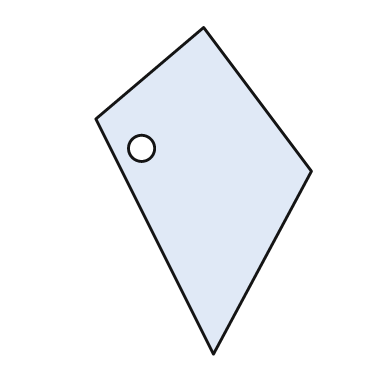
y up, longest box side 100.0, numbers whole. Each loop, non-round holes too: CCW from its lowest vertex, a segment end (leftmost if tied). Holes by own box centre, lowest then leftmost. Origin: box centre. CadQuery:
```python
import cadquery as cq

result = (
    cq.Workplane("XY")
    .moveTo(3.0, -50.0)
    .lineTo(33.0, 6.0)
    .lineTo(0.0, 50.0)
    .lineTo(-33.0, 22.0)
    .close()
    .moveTo(-19.0, 13.0)
    .circle(4.0)
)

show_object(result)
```